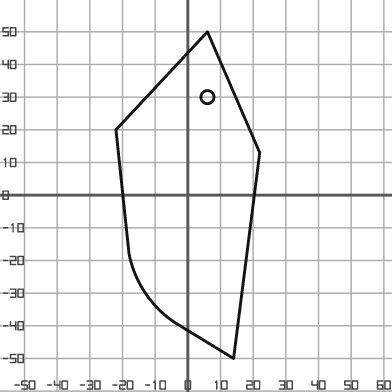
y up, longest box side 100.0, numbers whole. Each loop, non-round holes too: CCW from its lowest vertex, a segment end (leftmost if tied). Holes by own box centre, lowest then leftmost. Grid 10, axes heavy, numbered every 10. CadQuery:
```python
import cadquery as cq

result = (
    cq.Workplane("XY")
    .moveTo(14.0, -50.0)
    .lineTo(22.0, 13.0)
    .lineTo(6.0, 50.0)
    .lineTo(-22.0, 20.0)
    .lineTo(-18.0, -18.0)
    .threePointArc((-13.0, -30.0), (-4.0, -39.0))
    .close()
    .moveTo(6.0, 30.0)
    .circle(2.0)
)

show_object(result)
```